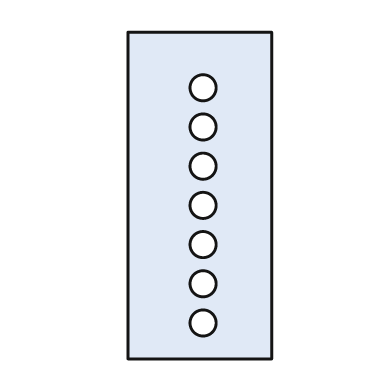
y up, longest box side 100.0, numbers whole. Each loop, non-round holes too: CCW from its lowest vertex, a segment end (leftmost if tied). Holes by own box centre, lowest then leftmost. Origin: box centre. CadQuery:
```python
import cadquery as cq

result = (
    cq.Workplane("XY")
    .moveTo(-22.0, -50.0)
    .lineTo(22.0, -50.0)
    .lineTo(22.0, 50.0)
    .lineTo(-22.0, 50.0)
    .close()
    .moveTo(1.0, -39.0)
    .circle(4.0)
    .moveTo(1.0, -27.0)
    .circle(4.0)
    .moveTo(1.0, -15.0)
    .circle(4.0)
    .moveTo(1.0, -3.0)
    .circle(4.0)
    .moveTo(1.0, 9.0)
    .circle(4.0)
    .moveTo(1.0, 21.0)
    .circle(4.0)
    .moveTo(1.0, 33.0)
    .circle(4.0)
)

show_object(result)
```